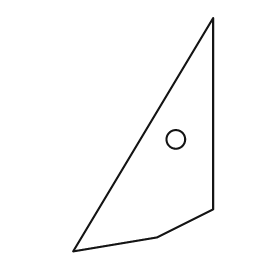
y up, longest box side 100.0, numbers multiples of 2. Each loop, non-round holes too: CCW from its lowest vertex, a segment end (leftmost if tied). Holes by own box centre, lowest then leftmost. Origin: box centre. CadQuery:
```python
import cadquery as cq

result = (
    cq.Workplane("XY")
    .moveTo(-30.0, -50.0)
    .lineTo(6.0, -44.0)
    .lineTo(30.0, -32.0)
    .lineTo(30.0, 50.0)
    .close()
    .moveTo(14.0, -2.0)
    .circle(4.0)
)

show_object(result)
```